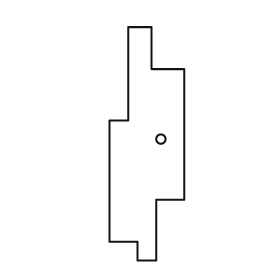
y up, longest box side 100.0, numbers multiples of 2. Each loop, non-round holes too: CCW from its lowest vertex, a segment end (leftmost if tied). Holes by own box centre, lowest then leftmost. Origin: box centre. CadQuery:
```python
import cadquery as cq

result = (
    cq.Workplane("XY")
    .moveTo(-4.0, -50.0)
    .lineTo(4.0, -50.0)
    .lineTo(4.0, -24.0)
    .lineTo(16.0, -24.0)
    .lineTo(16.0, 32.0)
    .lineTo(2.0, 32.0)
    .lineTo(2.0, 50.0)
    .lineTo(-8.0, 50.0)
    .lineTo(-8.0, 10.0)
    .lineTo(-16.0, 10.0)
    .lineTo(-16.0, -42.0)
    .lineTo(-4.0, -42.0)
    .close()
    .moveTo(6.0, 2.0)
    .circle(2.0)
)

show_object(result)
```